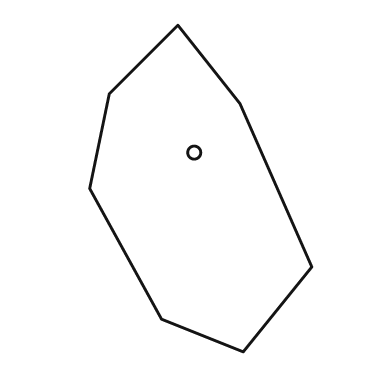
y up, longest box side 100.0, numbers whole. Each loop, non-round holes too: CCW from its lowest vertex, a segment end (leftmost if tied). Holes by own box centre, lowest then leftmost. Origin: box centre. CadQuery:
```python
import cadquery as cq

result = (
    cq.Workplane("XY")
    .moveTo(13.0, -50.0)
    .lineTo(34.0, -24.0)
    .lineTo(12.0, 26.0)
    .lineTo(-7.0, 50.0)
    .lineTo(-28.0, 29.0)
    .lineTo(-34.0, 0.0)
    .lineTo(-12.0, -40.0)
    .close()
    .moveTo(-2.0, 11.0)
    .circle(2.0)
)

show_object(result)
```